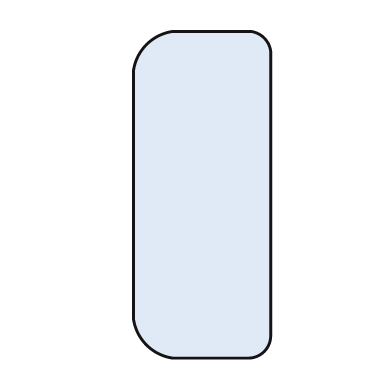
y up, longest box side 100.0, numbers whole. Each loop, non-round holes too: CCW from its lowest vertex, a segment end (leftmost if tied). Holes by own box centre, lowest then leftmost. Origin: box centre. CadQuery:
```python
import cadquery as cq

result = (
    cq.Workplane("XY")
    .moveTo(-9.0, -50.0)
    .lineTo(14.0, -50.0)
    .threePointArc((19.0, -48.0), (21.0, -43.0))
    .lineTo(21.0, 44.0)
    .threePointArc((19.0, 48.0), (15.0, 50.0))
    .lineTo(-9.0, 50.0)
    .threePointArc((-17.0, 46.0), (-21.0, 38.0))
    .lineTo(-21.0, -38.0)
    .threePointArc((-17.0, -46.0), (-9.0, -50.0))
    .close()
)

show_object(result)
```